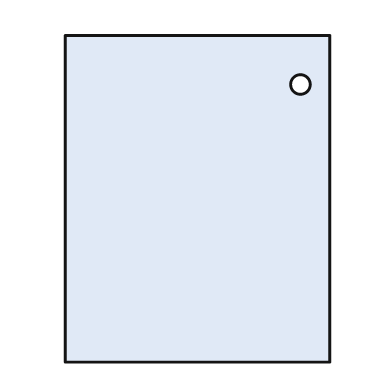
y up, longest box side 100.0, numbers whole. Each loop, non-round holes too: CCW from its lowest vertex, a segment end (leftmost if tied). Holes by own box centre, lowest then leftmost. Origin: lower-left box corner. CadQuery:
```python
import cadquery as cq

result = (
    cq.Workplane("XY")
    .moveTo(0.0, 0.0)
    .lineTo(81.0, 0.0)
    .lineTo(81.0, 100.0)
    .lineTo(0.0, 100.0)
    .close()
    .moveTo(72.0, 85.0)
    .circle(3.0)
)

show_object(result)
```